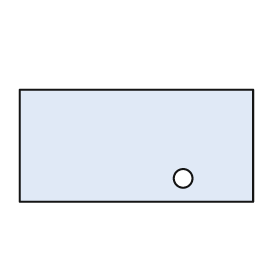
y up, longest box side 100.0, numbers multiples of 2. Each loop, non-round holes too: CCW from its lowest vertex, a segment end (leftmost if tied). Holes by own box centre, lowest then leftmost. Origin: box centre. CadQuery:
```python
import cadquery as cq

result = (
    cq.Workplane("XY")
    .moveTo(-50.0, -24.0)
    .lineTo(50.0, -24.0)
    .lineTo(50.0, 24.0)
    .lineTo(-50.0, 24.0)
    .close()
    .moveTo(20.0, -14.0)
    .circle(4.0)
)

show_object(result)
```